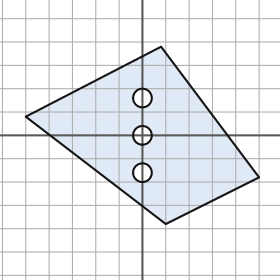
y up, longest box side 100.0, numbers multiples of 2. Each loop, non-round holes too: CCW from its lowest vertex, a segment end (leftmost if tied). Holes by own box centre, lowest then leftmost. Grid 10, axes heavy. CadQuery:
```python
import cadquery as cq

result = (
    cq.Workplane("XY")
    .moveTo(10.0, -38.0)
    .lineTo(50.0, -18.0)
    .lineTo(8.0, 38.0)
    .lineTo(-50.0, 8.0)
    .close()
    .moveTo(0.0, -16.0)
    .circle(4.0)
    .moveTo(0.0, 0.0)
    .circle(4.0)
    .moveTo(0.0, 16.0)
    .circle(4.0)
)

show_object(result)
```